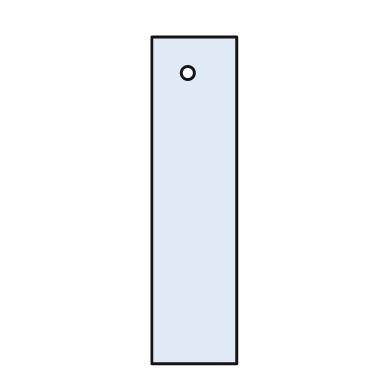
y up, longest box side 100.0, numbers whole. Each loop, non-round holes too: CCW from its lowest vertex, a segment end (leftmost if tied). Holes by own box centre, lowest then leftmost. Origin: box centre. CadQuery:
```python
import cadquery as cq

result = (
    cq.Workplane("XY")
    .moveTo(-13.0, -50.0)
    .lineTo(13.0, -50.0)
    .lineTo(13.0, 50.0)
    .lineTo(-13.0, 50.0)
    .close()
    .moveTo(-2.0, 39.0)
    .circle(2.0)
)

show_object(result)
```